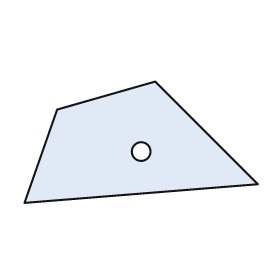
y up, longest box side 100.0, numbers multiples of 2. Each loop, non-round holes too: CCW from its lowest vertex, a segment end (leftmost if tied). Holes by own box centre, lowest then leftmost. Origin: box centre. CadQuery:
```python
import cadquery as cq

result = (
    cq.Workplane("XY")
    .moveTo(-50.0, -26.0)
    .lineTo(50.0, -18.0)
    .lineTo(6.0, 26.0)
    .lineTo(-36.0, 14.0)
    .close()
    .moveTo(0.0, -4.0)
    .circle(4.0)
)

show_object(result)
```